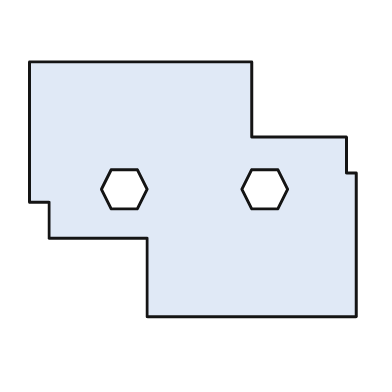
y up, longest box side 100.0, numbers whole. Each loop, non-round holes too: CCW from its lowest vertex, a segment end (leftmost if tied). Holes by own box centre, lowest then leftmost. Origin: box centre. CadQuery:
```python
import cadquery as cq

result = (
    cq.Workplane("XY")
    .moveTo(-14.0, -39.0)
    .lineTo(50.0, -39.0)
    .lineTo(50.0, 5.0)
    .lineTo(47.0, 5.0)
    .lineTo(47.0, 16.0)
    .lineTo(18.0, 16.0)
    .lineTo(18.0, 39.0)
    .lineTo(-50.0, 39.0)
    .lineTo(-50.0, -4.0)
    .lineTo(-44.0, -4.0)
    .lineTo(-44.0, -15.0)
    .lineTo(-14.0, -15.0)
    .close()
    .moveTo(-25.0, -6.0)
    .lineTo(-17.0, -6.0)
    .lineTo(-14.0, 0.0)
    .lineTo(-17.0, 6.0)
    .lineTo(-25.0, 6.0)
    .lineTo(-28.0, 0.0)
    .close()
    .moveTo(18.0, -6.0)
    .lineTo(26.0, -6.0)
    .lineTo(29.0, 0.0)
    .lineTo(26.0, 6.0)
    .lineTo(18.0, 6.0)
    .lineTo(15.0, 0.0)
    .close()
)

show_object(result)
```